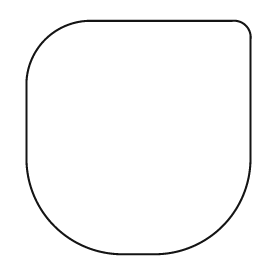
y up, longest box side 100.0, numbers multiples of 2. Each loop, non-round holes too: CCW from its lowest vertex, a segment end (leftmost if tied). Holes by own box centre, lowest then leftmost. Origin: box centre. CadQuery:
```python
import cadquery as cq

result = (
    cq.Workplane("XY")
    .moveTo(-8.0, -50.0)
    .lineTo(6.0, -50.0)
    .threePointArc((36.0, -38.0), (48.0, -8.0))
    .lineTo(48.0, 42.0)
    .threePointArc((46.0, 48.0), (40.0, 50.0))
    .lineTo(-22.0, 50.0)
    .threePointArc((-40.0, 42.0), (-48.0, 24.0))
    .lineTo(-48.0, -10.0)
    .threePointArc((-36.0, -38.0), (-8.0, -50.0))
    .close()
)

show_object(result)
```